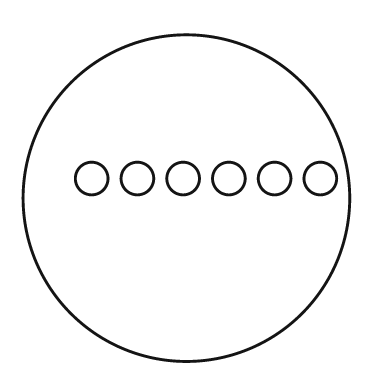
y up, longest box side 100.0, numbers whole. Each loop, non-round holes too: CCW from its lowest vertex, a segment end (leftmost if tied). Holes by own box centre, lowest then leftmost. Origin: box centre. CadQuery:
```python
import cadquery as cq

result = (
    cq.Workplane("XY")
    .moveTo(0.0, 0.0)
    .circle(50.0)
    .moveTo(-29.0, 6.0)
    .circle(5.0)
    .moveTo(-15.0, 6.0)
    .circle(5.0)
    .moveTo(-1.0, 6.0)
    .circle(5.0)
    .moveTo(13.0, 6.0)
    .circle(5.0)
    .moveTo(27.0, 6.0)
    .circle(5.0)
    .moveTo(41.0, 6.0)
    .circle(5.0)
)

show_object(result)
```